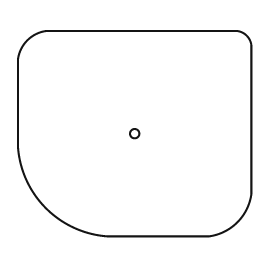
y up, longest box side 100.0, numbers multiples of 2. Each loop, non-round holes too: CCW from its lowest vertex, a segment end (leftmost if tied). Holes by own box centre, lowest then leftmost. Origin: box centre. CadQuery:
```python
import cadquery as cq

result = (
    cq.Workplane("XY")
    .moveTo(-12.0, -44.0)
    .lineTo(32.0, -44.0)
    .threePointArc((44.0, -38.0), (50.0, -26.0))
    .lineTo(50.0, 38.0)
    .threePointArc((48.0, 42.0), (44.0, 44.0))
    .lineTo(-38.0, 44.0)
    .threePointArc((-46.0, 40.0), (-50.0, 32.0))
    .lineTo(-50.0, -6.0)
    .threePointArc((-38.0, -32.0), (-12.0, -44.0))
    .close()
    .moveTo(0.0, 0.0)
    .circle(2.0)
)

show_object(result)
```